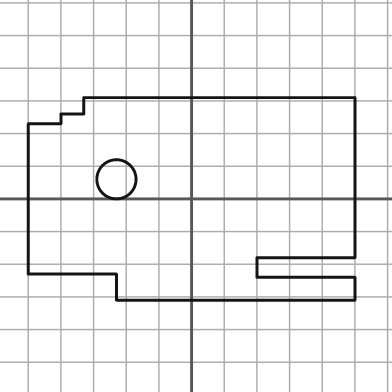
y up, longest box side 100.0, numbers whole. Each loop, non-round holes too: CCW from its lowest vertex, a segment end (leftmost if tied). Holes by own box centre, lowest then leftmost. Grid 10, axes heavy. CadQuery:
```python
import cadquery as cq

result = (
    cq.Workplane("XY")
    .moveTo(-23.0, -31.0)
    .lineTo(50.0, -31.0)
    .lineTo(50.0, -24.0)
    .lineTo(20.0, -24.0)
    .lineTo(20.0, -18.0)
    .lineTo(50.0, -18.0)
    .lineTo(50.0, 31.0)
    .lineTo(-33.0, 31.0)
    .lineTo(-33.0, 26.0)
    .lineTo(-40.0, 26.0)
    .lineTo(-40.0, 23.0)
    .lineTo(-50.0, 23.0)
    .lineTo(-50.0, -23.0)
    .lineTo(-23.0, -23.0)
    .close()
    .moveTo(-23.0, 6.0)
    .circle(6.0)
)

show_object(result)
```